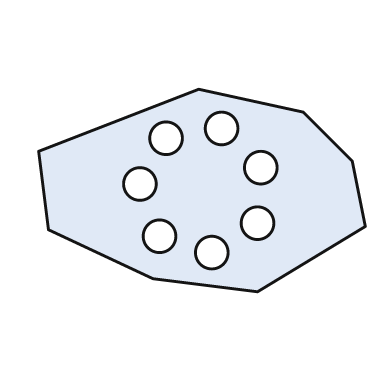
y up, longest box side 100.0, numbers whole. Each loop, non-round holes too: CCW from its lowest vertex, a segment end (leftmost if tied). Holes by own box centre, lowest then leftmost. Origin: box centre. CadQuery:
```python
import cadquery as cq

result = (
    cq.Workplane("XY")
    .moveTo(17.0, -31.0)
    .lineTo(50.0, -11.0)
    .lineTo(46.0, 9.0)
    .lineTo(31.0, 24.0)
    .lineTo(-1.0, 31.0)
    .lineTo(-50.0, 12.0)
    .lineTo(-47.0, -12.0)
    .lineTo(-15.0, -27.0)
    .close()
    .moveTo(3.0, -19.0)
    .circle(5.0)
    .moveTo(-13.0, -14.0)
    .circle(5.0)
    .moveTo(17.0, -10.0)
    .circle(5.0)
    .moveTo(-19.0, 2.0)
    .circle(5.0)
    .moveTo(18.0, 7.0)
    .circle(5.0)
    .moveTo(-11.0, 16.0)
    .circle(5.0)
    .moveTo(6.0, 19.0)
    .circle(5.0)
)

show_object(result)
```